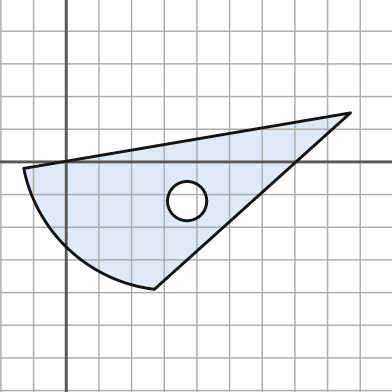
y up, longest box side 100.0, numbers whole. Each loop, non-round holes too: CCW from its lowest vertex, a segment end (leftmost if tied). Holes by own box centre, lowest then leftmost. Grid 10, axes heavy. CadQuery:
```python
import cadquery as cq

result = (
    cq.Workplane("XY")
    .moveTo(27.0, -39.0)
    .lineTo(87.0, 15.0)
    .lineTo(-13.0, -2.0)
    .threePointArc((1.0, -27.0), (27.0, -39.0))
    .close()
    .moveTo(37.0, -12.0)
    .circle(6.0)
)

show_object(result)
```